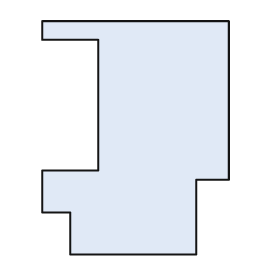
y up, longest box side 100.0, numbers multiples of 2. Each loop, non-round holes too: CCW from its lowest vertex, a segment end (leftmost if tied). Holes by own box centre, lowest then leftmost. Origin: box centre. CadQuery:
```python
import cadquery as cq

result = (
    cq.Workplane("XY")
    .moveTo(-28.0, -50.0)
    .lineTo(26.0, -50.0)
    .lineTo(26.0, -18.0)
    .lineTo(40.0, -18.0)
    .lineTo(40.0, 50.0)
    .lineTo(-40.0, 50.0)
    .lineTo(-40.0, 42.0)
    .lineTo(-16.0, 42.0)
    .lineTo(-16.0, -14.0)
    .lineTo(-40.0, -14.0)
    .lineTo(-40.0, -32.0)
    .lineTo(-28.0, -32.0)
    .close()
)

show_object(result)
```